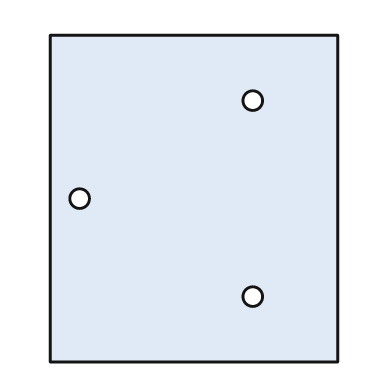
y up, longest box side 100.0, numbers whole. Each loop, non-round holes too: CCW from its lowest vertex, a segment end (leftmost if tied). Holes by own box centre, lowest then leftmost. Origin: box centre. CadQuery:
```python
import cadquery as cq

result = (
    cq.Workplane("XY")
    .moveTo(-44.0, -50.0)
    .lineTo(44.0, -50.0)
    .lineTo(44.0, 50.0)
    .lineTo(-44.0, 50.0)
    .close()
    .moveTo(18.0, -30.0)
    .circle(3.0)
    .moveTo(-35.0, 0.0)
    .circle(3.0)
    .moveTo(18.0, 30.0)
    .circle(3.0)
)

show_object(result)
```